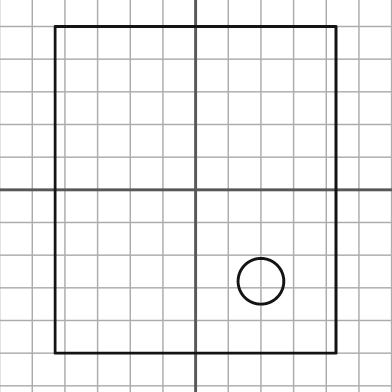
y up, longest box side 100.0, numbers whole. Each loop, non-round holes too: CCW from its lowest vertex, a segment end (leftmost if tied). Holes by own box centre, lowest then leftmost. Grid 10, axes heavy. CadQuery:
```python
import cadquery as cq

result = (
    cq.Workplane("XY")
    .moveTo(-43.0, -50.0)
    .lineTo(43.0, -50.0)
    .lineTo(43.0, 50.0)
    .lineTo(-43.0, 50.0)
    .close()
    .moveTo(20.0, -28.0)
    .circle(7.0)
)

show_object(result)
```